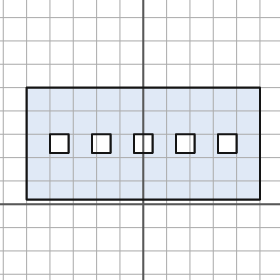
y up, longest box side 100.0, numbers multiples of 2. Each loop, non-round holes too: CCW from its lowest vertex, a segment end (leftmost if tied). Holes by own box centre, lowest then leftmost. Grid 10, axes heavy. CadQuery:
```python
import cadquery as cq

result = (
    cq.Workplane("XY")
    .moveTo(-50.0, 2.0)
    .lineTo(50.0, 2.0)
    .lineTo(50.0, 50.0)
    .lineTo(-50.0, 50.0)
    .close()
    .moveTo(-40.0, 22.0)
    .lineTo(-32.0, 22.0)
    .lineTo(-32.0, 30.0)
    .lineTo(-40.0, 30.0)
    .close()
    .moveTo(-22.0, 22.0)
    .lineTo(-14.0, 22.0)
    .lineTo(-14.0, 30.0)
    .lineTo(-22.0, 30.0)
    .close()
    .moveTo(-4.0, 22.0)
    .lineTo(4.0, 22.0)
    .lineTo(4.0, 30.0)
    .lineTo(-4.0, 30.0)
    .close()
    .moveTo(14.0, 22.0)
    .lineTo(22.0, 22.0)
    .lineTo(22.0, 30.0)
    .lineTo(14.0, 30.0)
    .close()
    .moveTo(32.0, 22.0)
    .lineTo(40.0, 22.0)
    .lineTo(40.0, 30.0)
    .lineTo(32.0, 30.0)
    .close()
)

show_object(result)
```